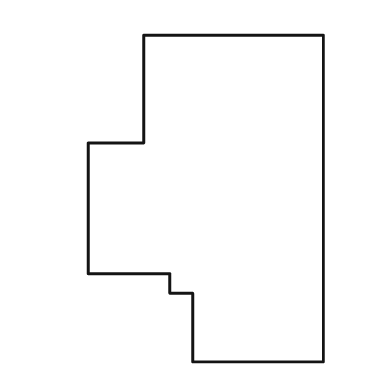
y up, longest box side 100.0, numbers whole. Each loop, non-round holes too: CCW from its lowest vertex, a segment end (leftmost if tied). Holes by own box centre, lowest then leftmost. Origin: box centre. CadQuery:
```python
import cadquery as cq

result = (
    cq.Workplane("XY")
    .moveTo(-4.0, -50.0)
    .lineTo(36.0, -50.0)
    .lineTo(36.0, 50.0)
    .lineTo(-19.0, 50.0)
    .lineTo(-19.0, 17.0)
    .lineTo(-36.0, 17.0)
    .lineTo(-36.0, -23.0)
    .lineTo(-11.0, -23.0)
    .lineTo(-11.0, -29.0)
    .lineTo(-4.0, -29.0)
    .close()
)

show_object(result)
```